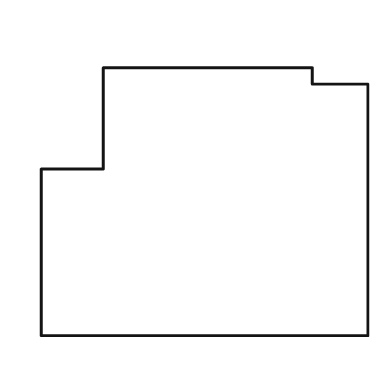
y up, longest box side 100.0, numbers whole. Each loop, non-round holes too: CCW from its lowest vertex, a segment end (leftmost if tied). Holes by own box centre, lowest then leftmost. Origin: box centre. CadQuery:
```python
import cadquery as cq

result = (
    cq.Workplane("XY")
    .moveTo(-50.0, -41.0)
    .lineTo(50.0, -41.0)
    .lineTo(50.0, 36.0)
    .lineTo(33.0, 36.0)
    .lineTo(33.0, 41.0)
    .lineTo(-31.0, 41.0)
    .lineTo(-31.0, 10.0)
    .lineTo(-50.0, 10.0)
    .close()
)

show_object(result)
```